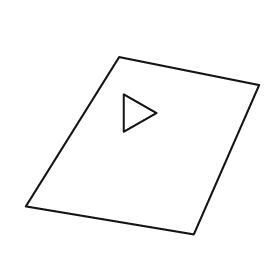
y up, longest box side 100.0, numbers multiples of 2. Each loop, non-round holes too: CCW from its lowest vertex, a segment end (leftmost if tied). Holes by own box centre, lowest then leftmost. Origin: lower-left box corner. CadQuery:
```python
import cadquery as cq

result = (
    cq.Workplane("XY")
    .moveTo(72.0, 0.0)
    .lineTo(100.0, 64.0)
    .lineTo(40.0, 76.0)
    .lineTo(0.0, 12.0)
    .close()
    .moveTo(42.0, 44.0)
    .lineTo(56.0, 52.0)
    .lineTo(42.0, 60.0)
    .close()
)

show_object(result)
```